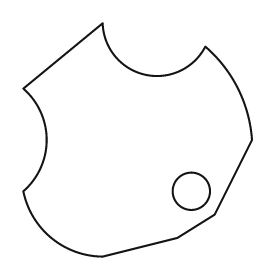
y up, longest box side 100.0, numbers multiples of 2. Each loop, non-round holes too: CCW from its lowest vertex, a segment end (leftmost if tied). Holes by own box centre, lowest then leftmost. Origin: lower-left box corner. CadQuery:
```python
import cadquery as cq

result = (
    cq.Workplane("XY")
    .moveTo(34.0, 0.0)
    .lineTo(66.0, 8.0)
    .lineTo(82.0, 18.0)
    .lineTo(98.0, 50.0)
    .threePointArc((92.0, 72.0), (78.0, 90.0))
    .threePointArc((52.0, 78.0), (34.0, 100.0))
    .lineTo(0.0, 72.0)
    .threePointArc((10.0, 50.0), (0.0, 28.0))
    .threePointArc((12.0, 8.0), (34.0, 0.0))
    .close()
    .moveTo(72.0, 28.0)
    .circle(8.0)
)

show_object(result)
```